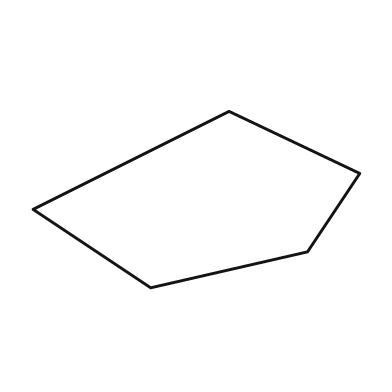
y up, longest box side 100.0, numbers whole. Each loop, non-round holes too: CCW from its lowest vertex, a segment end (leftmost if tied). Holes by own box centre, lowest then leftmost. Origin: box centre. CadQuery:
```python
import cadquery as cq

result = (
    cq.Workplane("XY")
    .moveTo(-14.0, -27.0)
    .lineTo(34.0, -16.0)
    .lineTo(50.0, 8.0)
    .lineTo(10.0, 27.0)
    .lineTo(-50.0, -3.0)
    .close()
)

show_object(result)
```